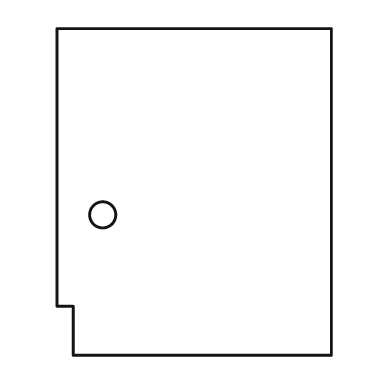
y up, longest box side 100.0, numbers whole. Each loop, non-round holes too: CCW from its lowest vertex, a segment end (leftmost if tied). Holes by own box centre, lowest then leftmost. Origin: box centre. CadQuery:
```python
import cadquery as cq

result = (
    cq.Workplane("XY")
    .moveTo(-37.0, -50.0)
    .lineTo(42.0, -50.0)
    .lineTo(42.0, 50.0)
    .lineTo(-42.0, 50.0)
    .lineTo(-42.0, -35.0)
    .lineTo(-37.0, -35.0)
    .close()
    .moveTo(-28.0, -7.0)
    .circle(4.0)
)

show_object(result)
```